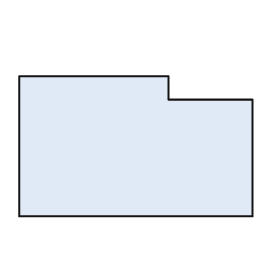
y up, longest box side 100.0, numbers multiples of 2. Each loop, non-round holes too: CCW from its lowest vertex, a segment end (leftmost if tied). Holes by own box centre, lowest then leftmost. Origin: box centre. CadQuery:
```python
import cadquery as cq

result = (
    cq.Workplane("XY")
    .moveTo(-50.0, -30.0)
    .lineTo(50.0, -30.0)
    .lineTo(50.0, 20.0)
    .lineTo(14.0, 20.0)
    .lineTo(14.0, 30.0)
    .lineTo(-50.0, 30.0)
    .close()
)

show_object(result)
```